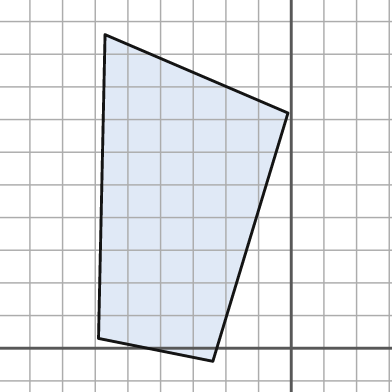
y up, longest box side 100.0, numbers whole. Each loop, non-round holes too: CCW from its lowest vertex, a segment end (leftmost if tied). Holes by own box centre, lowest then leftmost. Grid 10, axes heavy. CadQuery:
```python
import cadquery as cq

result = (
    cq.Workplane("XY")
    .moveTo(-24.0, -4.0)
    .lineTo(-1.0, 72.0)
    .lineTo(-57.0, 96.0)
    .lineTo(-59.0, 3.0)
    .close()
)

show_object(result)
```